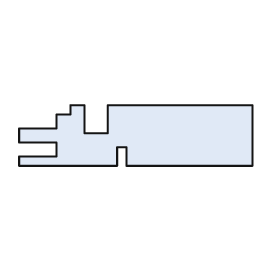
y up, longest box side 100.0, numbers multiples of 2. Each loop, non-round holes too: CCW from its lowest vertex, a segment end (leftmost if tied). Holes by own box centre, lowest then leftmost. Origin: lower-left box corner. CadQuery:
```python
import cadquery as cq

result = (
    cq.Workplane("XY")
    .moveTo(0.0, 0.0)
    .lineTo(42.0, 0.0)
    .lineTo(42.0, 8.0)
    .lineTo(46.0, 8.0)
    .lineTo(46.0, 0.0)
    .lineTo(100.0, 0.0)
    .lineTo(100.0, 26.0)
    .lineTo(38.0, 26.0)
    .lineTo(38.0, 14.0)
    .lineTo(28.0, 14.0)
    .lineTo(28.0, 26.0)
    .lineTo(22.0, 26.0)
    .lineTo(22.0, 22.0)
    .lineTo(16.0, 22.0)
    .lineTo(16.0, 16.0)
    .lineTo(0.0, 16.0)
    .lineTo(0.0, 10.0)
    .lineTo(16.0, 10.0)
    .lineTo(16.0, 4.0)
    .lineTo(0.0, 4.0)
    .close()
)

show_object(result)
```